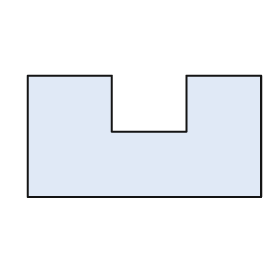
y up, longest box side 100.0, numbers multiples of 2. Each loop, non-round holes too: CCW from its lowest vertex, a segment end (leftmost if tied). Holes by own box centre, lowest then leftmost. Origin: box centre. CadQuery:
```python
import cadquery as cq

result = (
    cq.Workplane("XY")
    .moveTo(-50.0, -26.0)
    .lineTo(50.0, -26.0)
    .lineTo(50.0, 26.0)
    .lineTo(18.0, 26.0)
    .lineTo(18.0, 2.0)
    .lineTo(-14.0, 2.0)
    .lineTo(-14.0, 26.0)
    .lineTo(-50.0, 26.0)
    .close()
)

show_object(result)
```